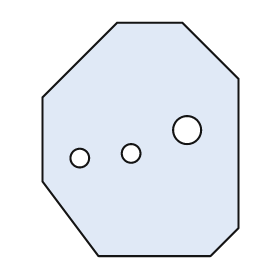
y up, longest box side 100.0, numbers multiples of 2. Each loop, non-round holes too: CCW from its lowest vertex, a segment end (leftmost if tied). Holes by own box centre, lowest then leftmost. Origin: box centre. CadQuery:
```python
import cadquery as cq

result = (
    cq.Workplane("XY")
    .moveTo(-18.0, -50.0)
    .lineTo(30.0, -50.0)
    .lineTo(42.0, -38.0)
    .lineTo(42.0, 26.0)
    .lineTo(18.0, 50.0)
    .lineTo(-10.0, 50.0)
    .lineTo(-42.0, 18.0)
    .lineTo(-42.0, -18.0)
    .close()
    .moveTo(-26.0, -8.0)
    .circle(4.0)
    .moveTo(-4.0, -6.0)
    .circle(4.0)
    .moveTo(20.0, 4.0)
    .circle(6.0)
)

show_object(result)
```